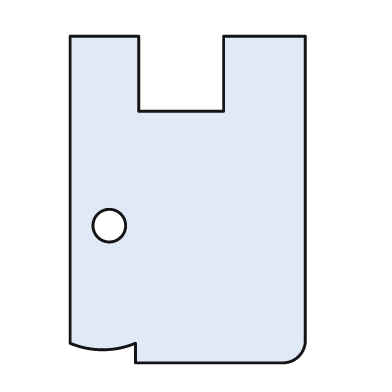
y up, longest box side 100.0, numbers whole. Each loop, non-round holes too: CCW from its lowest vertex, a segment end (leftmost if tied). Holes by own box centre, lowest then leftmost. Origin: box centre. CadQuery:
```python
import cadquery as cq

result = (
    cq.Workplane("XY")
    .moveTo(-16.0, -50.0)
    .lineTo(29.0, -50.0)
    .threePointArc((34.0, -48.0), (36.0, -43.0))
    .lineTo(36.0, 50.0)
    .lineTo(11.0, 50.0)
    .lineTo(11.0, 27.0)
    .lineTo(-15.0, 27.0)
    .lineTo(-15.0, 50.0)
    .lineTo(-36.0, 50.0)
    .lineTo(-36.0, -44.0)
    .threePointArc((-26.0, -46.0), (-16.0, -44.0))
    .close()
    .moveTo(-24.0, -8.0)
    .circle(5.0)
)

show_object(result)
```